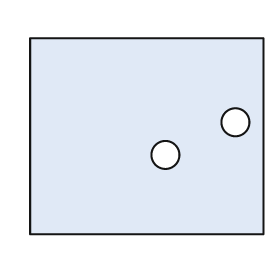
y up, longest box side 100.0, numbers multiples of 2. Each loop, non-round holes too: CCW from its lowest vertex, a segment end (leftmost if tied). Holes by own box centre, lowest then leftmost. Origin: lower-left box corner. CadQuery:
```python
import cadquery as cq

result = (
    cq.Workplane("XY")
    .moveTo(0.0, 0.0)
    .lineTo(100.0, 0.0)
    .lineTo(100.0, 84.0)
    .lineTo(0.0, 84.0)
    .close()
    .moveTo(58.0, 34.0)
    .circle(6.0)
    .moveTo(88.0, 48.0)
    .circle(6.0)
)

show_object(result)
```